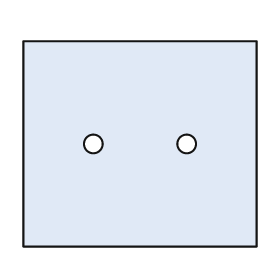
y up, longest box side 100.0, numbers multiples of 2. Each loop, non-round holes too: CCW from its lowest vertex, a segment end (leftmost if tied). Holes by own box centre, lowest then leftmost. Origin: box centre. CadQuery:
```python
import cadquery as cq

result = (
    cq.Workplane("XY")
    .moveTo(-50.0, -44.0)
    .lineTo(50.0, -44.0)
    .lineTo(50.0, 44.0)
    .lineTo(-50.0, 44.0)
    .close()
    .moveTo(-20.0, 0.0)
    .circle(4.0)
    .moveTo(20.0, 0.0)
    .circle(4.0)
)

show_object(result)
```